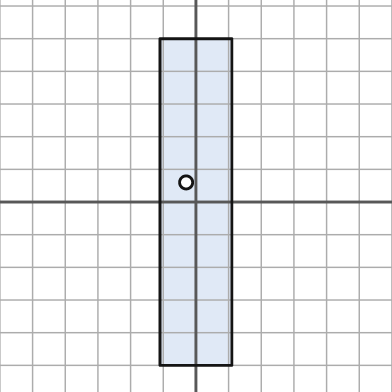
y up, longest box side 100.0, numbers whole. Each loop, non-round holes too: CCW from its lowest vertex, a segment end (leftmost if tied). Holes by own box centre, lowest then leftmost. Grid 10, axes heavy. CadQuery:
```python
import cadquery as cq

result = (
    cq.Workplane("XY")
    .moveTo(-11.0, -50.0)
    .lineTo(11.0, -50.0)
    .lineTo(11.0, 50.0)
    .lineTo(-11.0, 50.0)
    .close()
    .moveTo(-3.0, 6.0)
    .circle(2.0)
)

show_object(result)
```